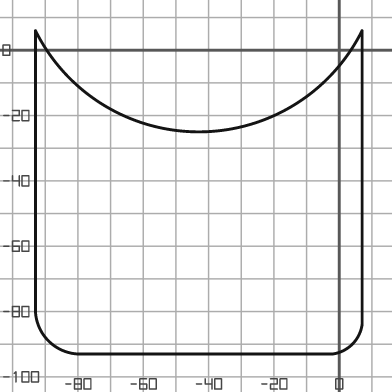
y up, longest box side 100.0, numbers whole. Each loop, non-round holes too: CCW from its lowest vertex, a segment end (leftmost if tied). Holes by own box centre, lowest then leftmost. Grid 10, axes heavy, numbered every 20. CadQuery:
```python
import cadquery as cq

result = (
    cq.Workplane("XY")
    .moveTo(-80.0, -93.0)
    .lineTo(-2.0, -93.0)
    .threePointArc((4.0, -90.0), (7.0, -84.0))
    .lineTo(7.0, 6.0)
    .threePointArc((-43.0, -25.0), (-93.0, 6.0))
    .lineTo(-93.0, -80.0)
    .threePointArc((-89.0, -89.0), (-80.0, -93.0))
    .close()
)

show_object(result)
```